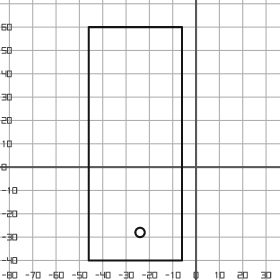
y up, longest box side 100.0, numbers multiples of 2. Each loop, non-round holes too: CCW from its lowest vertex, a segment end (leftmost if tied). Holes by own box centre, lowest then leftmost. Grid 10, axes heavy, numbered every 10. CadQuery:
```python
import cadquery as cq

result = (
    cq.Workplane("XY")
    .moveTo(-46.0, -40.0)
    .lineTo(-6.0, -40.0)
    .lineTo(-6.0, 60.0)
    .lineTo(-46.0, 60.0)
    .close()
    .moveTo(-24.0, -28.0)
    .circle(2.0)
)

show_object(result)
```